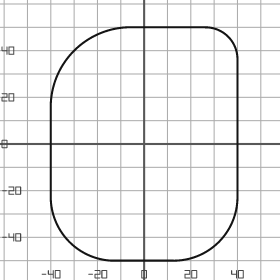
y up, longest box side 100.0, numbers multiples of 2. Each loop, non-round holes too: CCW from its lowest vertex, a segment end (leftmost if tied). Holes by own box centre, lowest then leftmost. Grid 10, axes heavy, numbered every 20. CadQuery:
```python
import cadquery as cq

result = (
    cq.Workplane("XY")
    .moveTo(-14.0, -50.0)
    .lineTo(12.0, -50.0)
    .threePointArc((32.0, -42.0), (40.0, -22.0))
    .lineTo(40.0, 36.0)
    .threePointArc((36.0, 46.0), (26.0, 50.0))
    .lineTo(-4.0, 50.0)
    .threePointArc((-30.0, 40.0), (-40.0, 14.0))
    .lineTo(-40.0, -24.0)
    .threePointArc((-32.0, -42.0), (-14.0, -50.0))
    .close()
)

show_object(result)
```